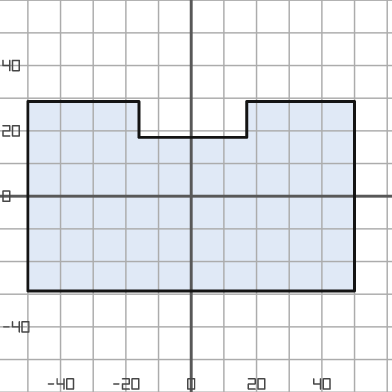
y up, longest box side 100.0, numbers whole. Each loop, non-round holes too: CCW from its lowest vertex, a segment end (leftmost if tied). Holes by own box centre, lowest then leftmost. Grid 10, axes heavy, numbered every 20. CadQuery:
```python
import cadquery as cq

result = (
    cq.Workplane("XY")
    .moveTo(-50.0, -29.0)
    .lineTo(50.0, -29.0)
    .lineTo(50.0, 29.0)
    .lineTo(17.0, 29.0)
    .lineTo(17.0, 18.0)
    .lineTo(-16.0, 18.0)
    .lineTo(-16.0, 29.0)
    .lineTo(-50.0, 29.0)
    .close()
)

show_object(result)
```